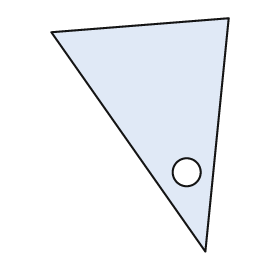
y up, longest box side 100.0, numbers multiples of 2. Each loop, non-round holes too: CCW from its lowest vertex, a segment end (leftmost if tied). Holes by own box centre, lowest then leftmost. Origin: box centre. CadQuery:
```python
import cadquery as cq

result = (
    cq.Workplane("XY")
    .moveTo(28.0, -50.0)
    .lineTo(38.0, 50.0)
    .lineTo(-38.0, 44.0)
    .close()
    .moveTo(20.0, -16.0)
    .circle(6.0)
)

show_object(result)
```